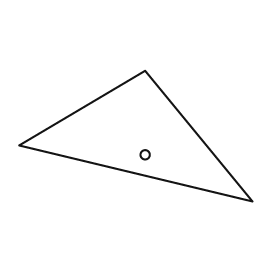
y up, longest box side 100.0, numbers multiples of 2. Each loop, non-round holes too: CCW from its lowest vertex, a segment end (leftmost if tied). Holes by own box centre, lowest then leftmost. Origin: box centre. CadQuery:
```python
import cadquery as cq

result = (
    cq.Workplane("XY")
    .moveTo(50.0, -28.0)
    .lineTo(4.0, 28.0)
    .lineTo(-50.0, -4.0)
    .close()
    .moveTo(4.0, -8.0)
    .circle(2.0)
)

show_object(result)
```